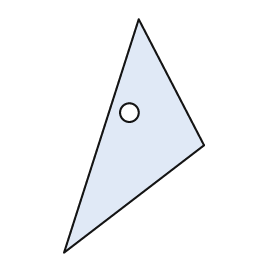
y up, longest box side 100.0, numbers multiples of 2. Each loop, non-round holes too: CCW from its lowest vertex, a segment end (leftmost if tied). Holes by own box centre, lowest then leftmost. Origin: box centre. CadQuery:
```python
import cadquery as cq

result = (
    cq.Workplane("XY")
    .moveTo(-30.0, -50.0)
    .lineTo(30.0, -4.0)
    .lineTo(2.0, 50.0)
    .close()
    .moveTo(-2.0, 10.0)
    .circle(4.0)
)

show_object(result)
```